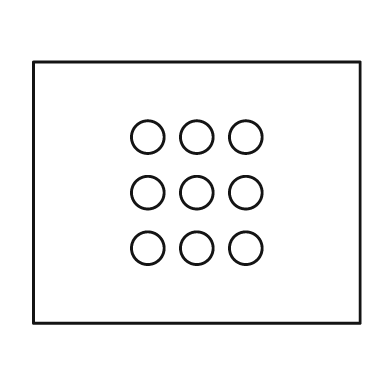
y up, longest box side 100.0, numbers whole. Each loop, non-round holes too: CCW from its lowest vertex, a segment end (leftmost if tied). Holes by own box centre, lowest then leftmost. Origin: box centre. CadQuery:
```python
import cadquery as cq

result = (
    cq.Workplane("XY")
    .moveTo(-50.0, -40.0)
    .lineTo(50.0, -40.0)
    .lineTo(50.0, 40.0)
    .lineTo(-50.0, 40.0)
    .close()
    .moveTo(-15.0, -17.0)
    .circle(5.0)
    .moveTo(0.0, -17.0)
    .circle(5.0)
    .moveTo(15.0, -17.0)
    .circle(5.0)
    .moveTo(-15.0, 0.0)
    .circle(5.0)
    .moveTo(0.0, 0.0)
    .circle(5.0)
    .moveTo(15.0, 0.0)
    .circle(5.0)
    .moveTo(-15.0, 17.0)
    .circle(5.0)
    .moveTo(0.0, 17.0)
    .circle(5.0)
    .moveTo(15.0, 17.0)
    .circle(5.0)
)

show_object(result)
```